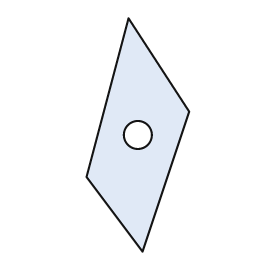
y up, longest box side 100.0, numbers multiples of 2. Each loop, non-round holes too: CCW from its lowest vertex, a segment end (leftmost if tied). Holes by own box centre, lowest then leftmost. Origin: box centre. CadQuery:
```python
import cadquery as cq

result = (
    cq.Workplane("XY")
    .moveTo(2.0, -50.0)
    .lineTo(22.0, 10.0)
    .lineTo(-4.0, 50.0)
    .lineTo(-22.0, -18.0)
    .close()
    .moveTo(0.0, 0.0)
    .circle(6.0)
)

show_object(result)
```